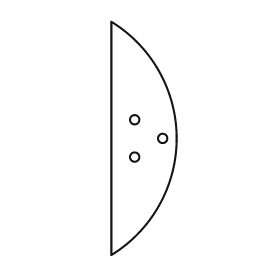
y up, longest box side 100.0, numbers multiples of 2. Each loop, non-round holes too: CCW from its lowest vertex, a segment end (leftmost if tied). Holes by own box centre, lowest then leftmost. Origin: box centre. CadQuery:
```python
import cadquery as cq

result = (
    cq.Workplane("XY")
    .moveTo(-14.0, -50.0)
    .threePointArc((14.0, 0.0), (-14.0, 50.0))
    .close()
    .moveTo(-4.0, -8.0)
    .circle(2.0)
    .moveTo(8.0, 0.0)
    .circle(2.0)
    .moveTo(-4.0, 8.0)
    .circle(2.0)
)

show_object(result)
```